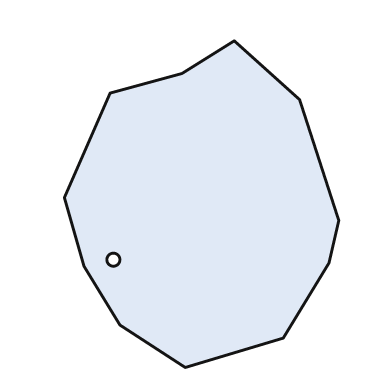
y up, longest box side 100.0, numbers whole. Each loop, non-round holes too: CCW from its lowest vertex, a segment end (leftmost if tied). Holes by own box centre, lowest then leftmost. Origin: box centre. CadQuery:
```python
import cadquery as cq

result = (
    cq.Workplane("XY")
    .moveTo(-5.0, -50.0)
    .lineTo(25.0, -41.0)
    .lineTo(39.0, -18.0)
    .lineTo(42.0, -5.0)
    .lineTo(30.0, 32.0)
    .lineTo(10.0, 50.0)
    .lineTo(-6.0, 40.0)
    .lineTo(-28.0, 34.0)
    .lineTo(-42.0, 2.0)
    .lineTo(-36.0, -19.0)
    .lineTo(-25.0, -37.0)
    .close()
    .moveTo(-27.0, -17.0)
    .circle(2.0)
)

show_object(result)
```